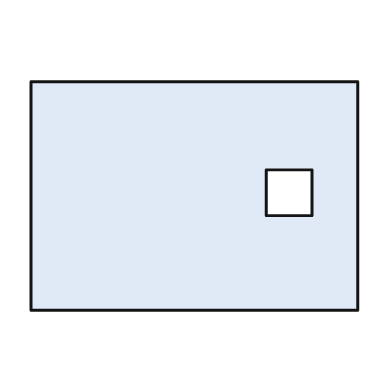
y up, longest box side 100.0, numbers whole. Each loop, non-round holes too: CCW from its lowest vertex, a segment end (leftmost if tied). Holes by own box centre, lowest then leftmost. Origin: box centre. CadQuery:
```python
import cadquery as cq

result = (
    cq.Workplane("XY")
    .moveTo(-50.0, -35.0)
    .lineTo(50.0, -35.0)
    .lineTo(50.0, 35.0)
    .lineTo(-50.0, 35.0)
    .close()
    .moveTo(22.0, -6.0)
    .lineTo(36.0, -6.0)
    .lineTo(36.0, 8.0)
    .lineTo(22.0, 8.0)
    .close()
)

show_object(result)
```